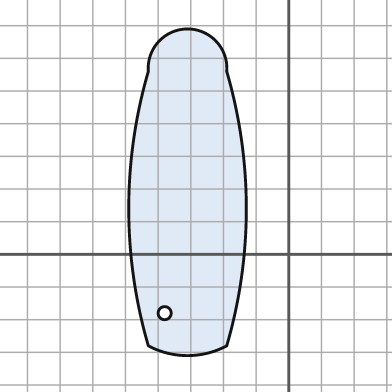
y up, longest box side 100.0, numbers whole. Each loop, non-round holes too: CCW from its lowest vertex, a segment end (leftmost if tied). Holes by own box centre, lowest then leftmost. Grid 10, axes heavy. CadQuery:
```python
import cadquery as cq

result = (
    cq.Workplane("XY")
    .moveTo(-43.0, -28.0)
    .threePointArc((-31.0, -31.0), (-19.0, -28.0))
    .threePointArc((-13.0, 14.0), (-19.0, 56.0))
    .threePointArc((-31.0, 69.0), (-43.0, 56.0))
    .threePointArc((-49.0, 14.0), (-43.0, -28.0))
    .close()
    .moveTo(-38.0, -18.0)
    .circle(2.0)
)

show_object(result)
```